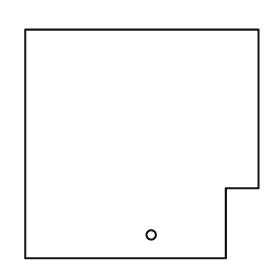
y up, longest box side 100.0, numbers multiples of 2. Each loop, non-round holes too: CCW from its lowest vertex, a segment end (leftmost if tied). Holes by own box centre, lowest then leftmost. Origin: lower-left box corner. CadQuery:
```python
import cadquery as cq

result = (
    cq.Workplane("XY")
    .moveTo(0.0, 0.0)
    .lineTo(86.0, 0.0)
    .lineTo(86.0, 30.0)
    .lineTo(100.0, 30.0)
    .lineTo(100.0, 98.0)
    .lineTo(0.0, 98.0)
    .close()
    .moveTo(54.0, 10.0)
    .circle(2.0)
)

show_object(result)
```